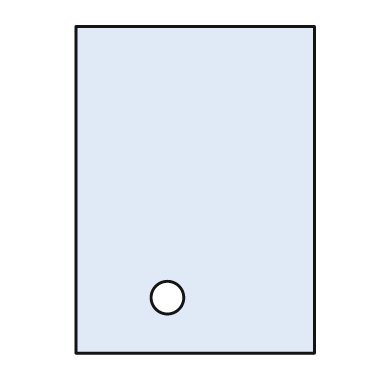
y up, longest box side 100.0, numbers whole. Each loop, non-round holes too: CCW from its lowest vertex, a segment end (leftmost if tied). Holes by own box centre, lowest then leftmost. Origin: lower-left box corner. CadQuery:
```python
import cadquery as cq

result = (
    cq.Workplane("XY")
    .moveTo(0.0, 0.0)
    .lineTo(73.0, 0.0)
    .lineTo(73.0, 100.0)
    .lineTo(0.0, 100.0)
    .close()
    .moveTo(28.0, 17.0)
    .circle(5.0)
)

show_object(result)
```